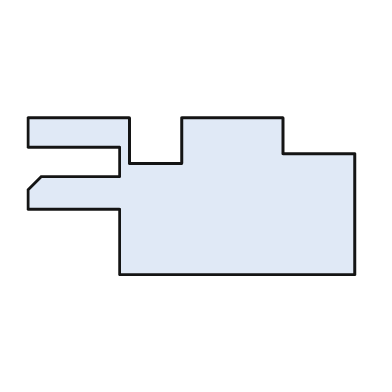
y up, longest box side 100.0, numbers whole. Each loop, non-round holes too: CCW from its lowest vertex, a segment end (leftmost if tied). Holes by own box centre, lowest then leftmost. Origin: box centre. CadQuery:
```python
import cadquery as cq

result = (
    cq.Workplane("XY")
    .moveTo(-22.0, -24.0)
    .lineTo(50.0, -24.0)
    .lineTo(50.0, 13.0)
    .lineTo(28.0, 13.0)
    .lineTo(28.0, 24.0)
    .lineTo(-3.0, 24.0)
    .lineTo(-3.0, 10.0)
    .lineTo(-19.0, 10.0)
    .lineTo(-19.0, 24.0)
    .lineTo(-50.0, 24.0)
    .lineTo(-50.0, 15.0)
    .lineTo(-22.0, 15.0)
    .lineTo(-22.0, 6.0)
    .lineTo(-46.0, 6.0)
    .lineTo(-50.0, 2.0)
    .lineTo(-50.0, -4.0)
    .lineTo(-22.0, -4.0)
    .close()
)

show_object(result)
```